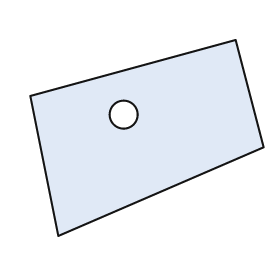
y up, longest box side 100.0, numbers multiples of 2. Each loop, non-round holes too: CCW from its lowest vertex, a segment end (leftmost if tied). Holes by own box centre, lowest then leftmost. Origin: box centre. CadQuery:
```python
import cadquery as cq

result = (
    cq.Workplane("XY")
    .moveTo(-38.0, -42.0)
    .lineTo(50.0, -4.0)
    .lineTo(38.0, 42.0)
    .lineTo(-50.0, 18.0)
    .close()
    .moveTo(-10.0, 10.0)
    .circle(6.0)
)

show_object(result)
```